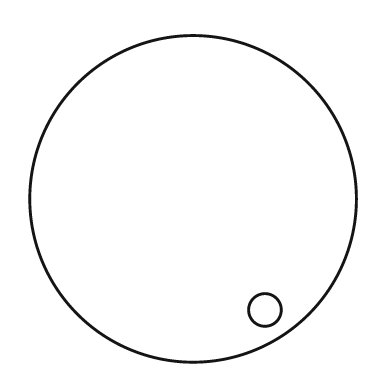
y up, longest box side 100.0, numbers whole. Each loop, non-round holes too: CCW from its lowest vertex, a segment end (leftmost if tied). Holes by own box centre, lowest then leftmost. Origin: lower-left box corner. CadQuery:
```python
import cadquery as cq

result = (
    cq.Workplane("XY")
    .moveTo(50.0, 50.0)
    .circle(50.0)
    .moveTo(72.0, 16.0)
    .circle(5.0)
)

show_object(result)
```